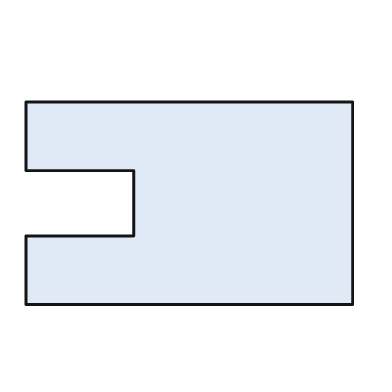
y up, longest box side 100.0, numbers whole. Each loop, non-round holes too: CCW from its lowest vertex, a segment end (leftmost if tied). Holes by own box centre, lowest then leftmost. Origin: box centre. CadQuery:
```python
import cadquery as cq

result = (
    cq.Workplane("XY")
    .moveTo(-50.0, -31.0)
    .lineTo(50.0, -31.0)
    .lineTo(50.0, 31.0)
    .lineTo(-50.0, 31.0)
    .lineTo(-50.0, 10.0)
    .lineTo(-17.0, 10.0)
    .lineTo(-17.0, -10.0)
    .lineTo(-50.0, -10.0)
    .close()
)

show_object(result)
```